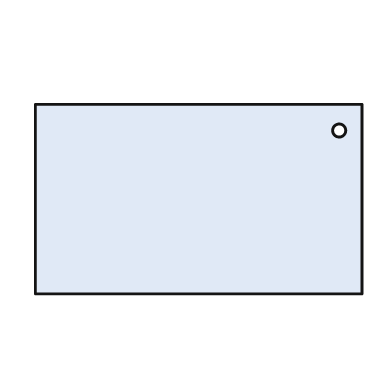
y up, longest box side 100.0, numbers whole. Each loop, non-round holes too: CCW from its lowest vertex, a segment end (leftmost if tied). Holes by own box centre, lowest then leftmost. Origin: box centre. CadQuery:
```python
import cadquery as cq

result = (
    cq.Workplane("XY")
    .moveTo(-50.0, -29.0)
    .lineTo(50.0, -29.0)
    .lineTo(50.0, 29.0)
    .lineTo(-50.0, 29.0)
    .close()
    .moveTo(43.0, 21.0)
    .circle(2.0)
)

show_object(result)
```